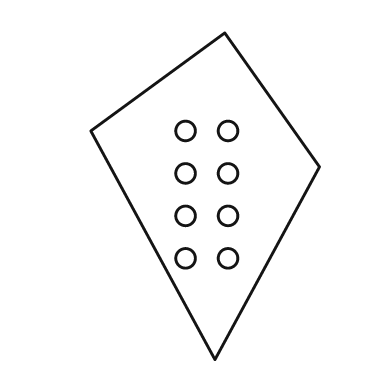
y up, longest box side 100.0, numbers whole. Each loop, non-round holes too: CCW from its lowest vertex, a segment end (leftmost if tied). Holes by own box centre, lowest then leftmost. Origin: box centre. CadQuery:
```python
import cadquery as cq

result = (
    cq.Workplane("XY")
    .moveTo(3.0, -50.0)
    .lineTo(35.0, 9.0)
    .lineTo(6.0, 50.0)
    .lineTo(-35.0, 20.0)
    .close()
    .moveTo(-6.0, -19.0)
    .circle(3.0)
    .moveTo(7.0, -19.0)
    .circle(3.0)
    .moveTo(-6.0, -6.0)
    .circle(3.0)
    .moveTo(7.0, -6.0)
    .circle(3.0)
    .moveTo(-6.0, 7.0)
    .circle(3.0)
    .moveTo(7.0, 7.0)
    .circle(3.0)
    .moveTo(-6.0, 20.0)
    .circle(3.0)
    .moveTo(7.0, 20.0)
    .circle(3.0)
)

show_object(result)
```